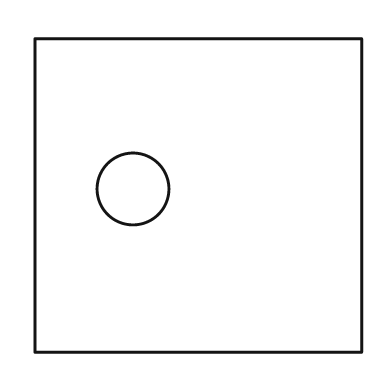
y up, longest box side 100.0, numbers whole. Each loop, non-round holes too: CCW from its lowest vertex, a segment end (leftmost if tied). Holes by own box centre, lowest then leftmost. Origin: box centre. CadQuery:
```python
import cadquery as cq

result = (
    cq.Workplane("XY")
    .moveTo(-50.0, -48.0)
    .lineTo(50.0, -48.0)
    .lineTo(50.0, 48.0)
    .lineTo(-50.0, 48.0)
    .close()
    .moveTo(-20.0, 2.0)
    .circle(11.0)
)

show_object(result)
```